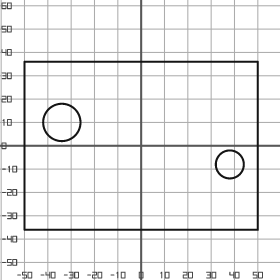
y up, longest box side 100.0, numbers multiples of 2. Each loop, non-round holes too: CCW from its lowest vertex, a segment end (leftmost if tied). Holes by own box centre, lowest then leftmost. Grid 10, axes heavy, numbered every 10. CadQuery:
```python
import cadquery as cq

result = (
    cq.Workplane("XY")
    .moveTo(-50.0, -36.0)
    .lineTo(50.0, -36.0)
    .lineTo(50.0, 36.0)
    .lineTo(-50.0, 36.0)
    .close()
    .moveTo(38.0, -8.0)
    .circle(6.0)
    .moveTo(-34.0, 10.0)
    .circle(8.0)
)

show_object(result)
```